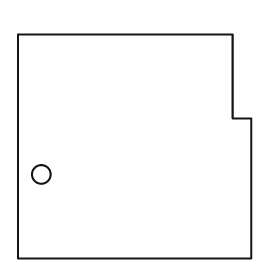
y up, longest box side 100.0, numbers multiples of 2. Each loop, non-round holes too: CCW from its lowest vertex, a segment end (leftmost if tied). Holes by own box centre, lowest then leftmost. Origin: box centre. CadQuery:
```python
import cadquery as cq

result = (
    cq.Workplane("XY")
    .moveTo(-50.0, -48.0)
    .lineTo(50.0, -48.0)
    .lineTo(50.0, 12.0)
    .lineTo(42.0, 12.0)
    .lineTo(42.0, 48.0)
    .lineTo(-50.0, 48.0)
    .close()
    .moveTo(-40.0, -12.0)
    .circle(4.0)
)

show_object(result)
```